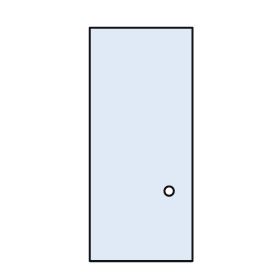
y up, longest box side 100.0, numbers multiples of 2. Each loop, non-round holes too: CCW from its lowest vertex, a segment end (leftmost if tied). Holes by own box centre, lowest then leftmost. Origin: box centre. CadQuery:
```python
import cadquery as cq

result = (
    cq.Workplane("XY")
    .moveTo(-22.0, -50.0)
    .lineTo(22.0, -50.0)
    .lineTo(22.0, 50.0)
    .lineTo(-22.0, 50.0)
    .close()
    .moveTo(12.0, -20.0)
    .circle(2.0)
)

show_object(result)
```